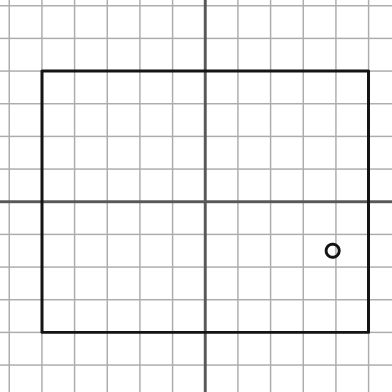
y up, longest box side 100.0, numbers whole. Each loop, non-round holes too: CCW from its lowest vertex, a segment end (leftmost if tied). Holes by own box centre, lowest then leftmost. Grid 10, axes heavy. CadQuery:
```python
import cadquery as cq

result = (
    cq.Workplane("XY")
    .moveTo(-50.0, -40.0)
    .lineTo(50.0, -40.0)
    .lineTo(50.0, 40.0)
    .lineTo(-50.0, 40.0)
    .close()
    .moveTo(39.0, -15.0)
    .circle(2.0)
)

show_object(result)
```